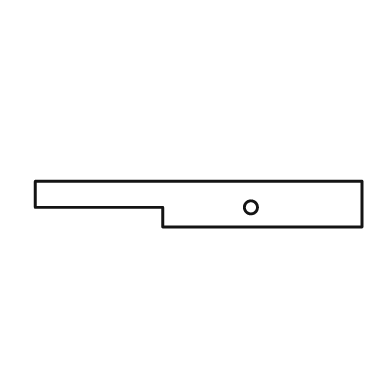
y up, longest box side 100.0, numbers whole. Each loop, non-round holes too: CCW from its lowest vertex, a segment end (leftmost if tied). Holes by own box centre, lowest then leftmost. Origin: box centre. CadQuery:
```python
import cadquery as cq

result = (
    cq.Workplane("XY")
    .moveTo(-11.0, -7.0)
    .lineTo(50.0, -7.0)
    .lineTo(50.0, 7.0)
    .lineTo(-50.0, 7.0)
    .lineTo(-50.0, -1.0)
    .lineTo(-11.0, -1.0)
    .close()
    .moveTo(16.0, -1.0)
    .circle(2.0)
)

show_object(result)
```